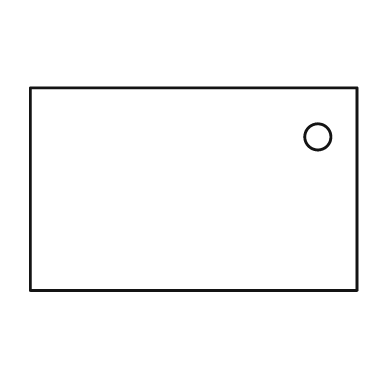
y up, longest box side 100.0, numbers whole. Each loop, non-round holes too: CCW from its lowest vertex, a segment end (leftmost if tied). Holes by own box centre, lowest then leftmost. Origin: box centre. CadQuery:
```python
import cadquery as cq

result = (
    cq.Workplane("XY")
    .moveTo(-50.0, -31.0)
    .lineTo(50.0, -31.0)
    .lineTo(50.0, 31.0)
    .lineTo(-50.0, 31.0)
    .close()
    .moveTo(38.0, 16.0)
    .circle(4.0)
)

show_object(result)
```